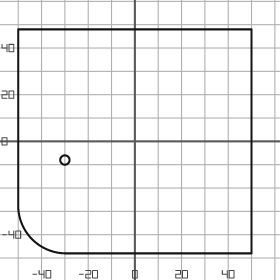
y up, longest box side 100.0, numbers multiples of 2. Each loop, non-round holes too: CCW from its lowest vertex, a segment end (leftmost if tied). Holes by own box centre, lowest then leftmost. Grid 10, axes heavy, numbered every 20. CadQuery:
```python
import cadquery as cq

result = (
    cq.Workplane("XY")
    .moveTo(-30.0, -48.0)
    .lineTo(50.0, -48.0)
    .lineTo(50.0, 48.0)
    .lineTo(-50.0, 48.0)
    .lineTo(-50.0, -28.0)
    .threePointArc((-44.0, -42.0), (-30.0, -48.0))
    .close()
    .moveTo(-30.0, -8.0)
    .circle(2.0)
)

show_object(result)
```